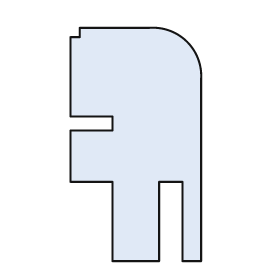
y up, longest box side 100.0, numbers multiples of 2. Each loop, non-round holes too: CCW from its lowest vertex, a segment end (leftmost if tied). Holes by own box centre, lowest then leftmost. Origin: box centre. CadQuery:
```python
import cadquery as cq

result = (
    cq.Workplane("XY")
    .moveTo(-10.0, -50.0)
    .lineTo(10.0, -50.0)
    .lineTo(10.0, -16.0)
    .lineTo(20.0, -16.0)
    .lineTo(20.0, -50.0)
    .lineTo(28.0, -50.0)
    .lineTo(28.0, 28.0)
    .threePointArc((22.0, 44.0), (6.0, 50.0))
    .lineTo(-24.0, 50.0)
    .lineTo(-24.0, 46.0)
    .lineTo(-28.0, 46.0)
    .lineTo(-28.0, 12.0)
    .lineTo(-10.0, 12.0)
    .lineTo(-10.0, 6.0)
    .lineTo(-28.0, 6.0)
    .lineTo(-28.0, -16.0)
    .lineTo(-10.0, -16.0)
    .close()
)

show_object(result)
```